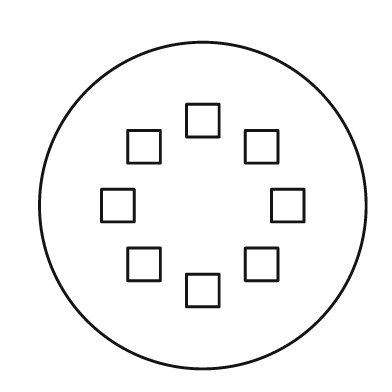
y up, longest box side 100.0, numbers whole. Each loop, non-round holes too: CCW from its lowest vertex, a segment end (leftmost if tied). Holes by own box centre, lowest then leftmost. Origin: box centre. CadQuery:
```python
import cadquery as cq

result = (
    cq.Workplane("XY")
    .moveTo(0.0, 0.0)
    .circle(50.0)
    .moveTo(-5.0, -31.0)
    .lineTo(5.0, -31.0)
    .lineTo(5.0, -21.0)
    .lineTo(-5.0, -21.0)
    .close()
    .moveTo(-23.0, -23.0)
    .lineTo(-13.0, -23.0)
    .lineTo(-13.0, -13.0)
    .lineTo(-23.0, -13.0)
    .close()
    .moveTo(13.0, -23.0)
    .lineTo(23.0, -23.0)
    .lineTo(23.0, -13.0)
    .lineTo(13.0, -13.0)
    .close()
    .moveTo(-31.0, -5.0)
    .lineTo(-21.0, -5.0)
    .lineTo(-21.0, 5.0)
    .lineTo(-31.0, 5.0)
    .close()
    .moveTo(21.0, -5.0)
    .lineTo(31.0, -5.0)
    .lineTo(31.0, 5.0)
    .lineTo(21.0, 5.0)
    .close()
    .moveTo(-23.0, 13.0)
    .lineTo(-13.0, 13.0)
    .lineTo(-13.0, 23.0)
    .lineTo(-23.0, 23.0)
    .close()
    .moveTo(13.0, 13.0)
    .lineTo(23.0, 13.0)
    .lineTo(23.0, 23.0)
    .lineTo(13.0, 23.0)
    .close()
    .moveTo(-5.0, 21.0)
    .lineTo(5.0, 21.0)
    .lineTo(5.0, 31.0)
    .lineTo(-5.0, 31.0)
    .close()
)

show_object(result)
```